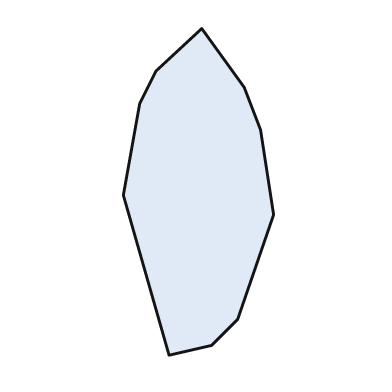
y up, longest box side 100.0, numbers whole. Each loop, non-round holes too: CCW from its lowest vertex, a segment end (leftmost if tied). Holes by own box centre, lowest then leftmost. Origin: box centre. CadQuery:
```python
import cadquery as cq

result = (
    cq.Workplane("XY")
    .moveTo(-9.0, -50.0)
    .lineTo(4.0, -47.0)
    .lineTo(12.0, -39.0)
    .lineTo(23.0, -7.0)
    .lineTo(19.0, 19.0)
    .lineTo(14.0, 32.0)
    .lineTo(1.0, 50.0)
    .lineTo(-13.0, 37.0)
    .lineTo(-18.0, 27.0)
    .lineTo(-23.0, -1.0)
    .close()
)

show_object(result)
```